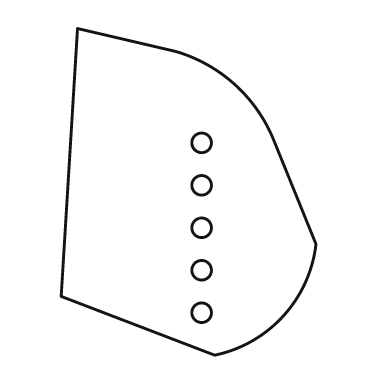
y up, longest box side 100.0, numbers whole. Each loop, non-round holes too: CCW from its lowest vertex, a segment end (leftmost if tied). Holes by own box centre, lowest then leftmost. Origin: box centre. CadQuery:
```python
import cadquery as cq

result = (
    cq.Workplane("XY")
    .moveTo(8.0, -50.0)
    .threePointArc((29.0, -38.0), (39.0, -16.0))
    .lineTo(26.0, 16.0)
    .threePointArc((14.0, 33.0), (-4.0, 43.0))
    .lineTo(-34.0, 50.0)
    .lineTo(-39.0, -32.0)
    .close()
    .moveTo(4.0, -37.0)
    .circle(3.0)
    .moveTo(4.0, -24.0)
    .circle(3.0)
    .moveTo(4.0, -11.0)
    .circle(3.0)
    .moveTo(4.0, 2.0)
    .circle(3.0)
    .moveTo(4.0, 15.0)
    .circle(3.0)
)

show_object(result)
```